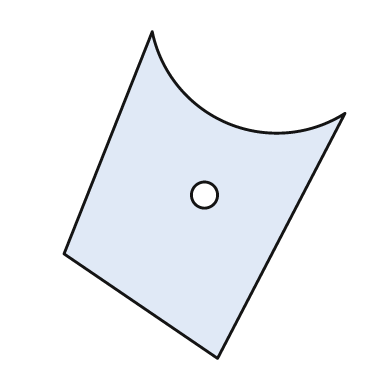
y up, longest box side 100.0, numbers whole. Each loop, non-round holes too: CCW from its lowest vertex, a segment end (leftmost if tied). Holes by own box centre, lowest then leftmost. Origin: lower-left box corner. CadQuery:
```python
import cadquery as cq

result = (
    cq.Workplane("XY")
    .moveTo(47.0, 0.0)
    .lineTo(86.0, 75.0)
    .threePointArc((50.0, 72.0), (27.0, 100.0))
    .lineTo(0.0, 32.0)
    .close()
    .moveTo(43.0, 50.0)
    .circle(4.0)
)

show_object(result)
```